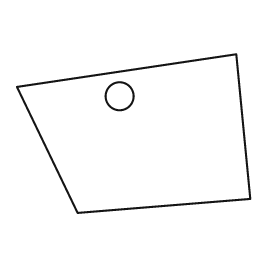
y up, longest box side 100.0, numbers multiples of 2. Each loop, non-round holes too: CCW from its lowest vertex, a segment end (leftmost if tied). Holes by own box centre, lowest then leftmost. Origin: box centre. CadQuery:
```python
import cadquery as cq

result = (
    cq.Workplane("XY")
    .moveTo(-24.0, -34.0)
    .lineTo(50.0, -28.0)
    .lineTo(44.0, 34.0)
    .lineTo(-50.0, 20.0)
    .close()
    .moveTo(-6.0, 16.0)
    .circle(6.0)
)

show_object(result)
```